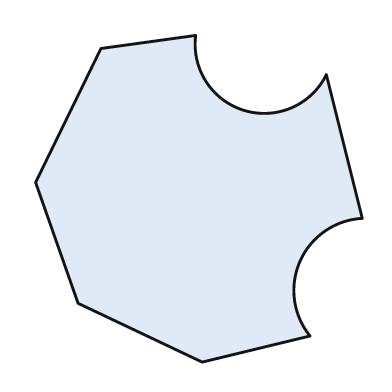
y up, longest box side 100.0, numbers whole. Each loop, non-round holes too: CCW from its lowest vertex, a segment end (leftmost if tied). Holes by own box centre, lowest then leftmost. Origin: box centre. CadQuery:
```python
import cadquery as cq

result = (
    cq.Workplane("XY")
    .moveTo(1.0, -50.0)
    .lineTo(34.0, -42.0)
    .threePointArc((31.0, -19.0), (50.0, -6.0))
    .lineTo(39.0, 38.0)
    .threePointArc((14.0, 27.0), (-1.0, 50.0))
    .lineTo(-30.0, 46.0)
    .lineTo(-50.0, 5.0)
    .lineTo(-37.0, -32.0)
    .close()
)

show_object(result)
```